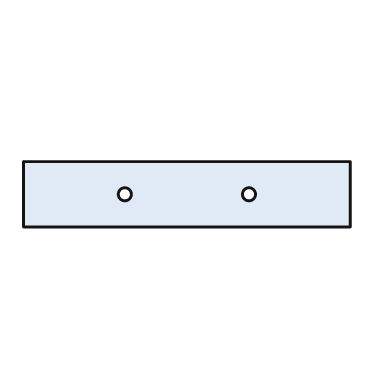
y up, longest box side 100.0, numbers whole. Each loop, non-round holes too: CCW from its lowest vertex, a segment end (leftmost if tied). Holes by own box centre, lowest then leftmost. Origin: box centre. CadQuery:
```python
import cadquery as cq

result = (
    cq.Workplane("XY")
    .moveTo(-50.0, -10.0)
    .lineTo(50.0, -10.0)
    .lineTo(50.0, 10.0)
    .lineTo(-50.0, 10.0)
    .close()
    .moveTo(-19.0, 0.0)
    .circle(2.0)
    .moveTo(19.0, 0.0)
    .circle(2.0)
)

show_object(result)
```